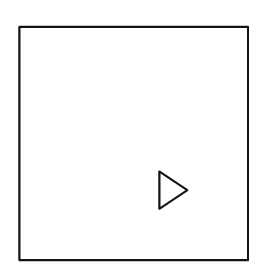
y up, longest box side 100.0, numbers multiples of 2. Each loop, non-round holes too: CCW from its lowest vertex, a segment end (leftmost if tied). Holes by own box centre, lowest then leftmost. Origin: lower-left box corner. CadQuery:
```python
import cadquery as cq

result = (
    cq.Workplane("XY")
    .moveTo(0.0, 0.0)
    .lineTo(98.0, 0.0)
    .lineTo(98.0, 100.0)
    .lineTo(0.0, 100.0)
    .close()
    .moveTo(60.0, 22.0)
    .lineTo(72.0, 30.0)
    .lineTo(60.0, 38.0)
    .close()
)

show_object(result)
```